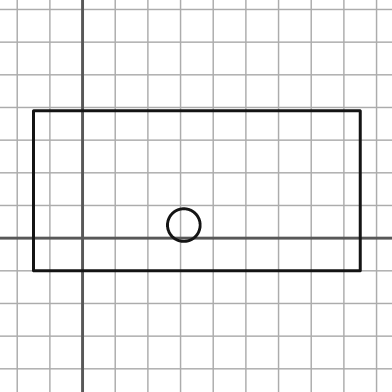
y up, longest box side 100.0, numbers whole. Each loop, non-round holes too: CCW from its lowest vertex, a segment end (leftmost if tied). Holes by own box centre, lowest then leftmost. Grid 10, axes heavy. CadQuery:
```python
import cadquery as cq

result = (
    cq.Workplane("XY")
    .moveTo(-15.0, -10.0)
    .lineTo(85.0, -10.0)
    .lineTo(85.0, 39.0)
    .lineTo(-15.0, 39.0)
    .close()
    .moveTo(31.0, 4.0)
    .circle(5.0)
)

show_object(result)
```